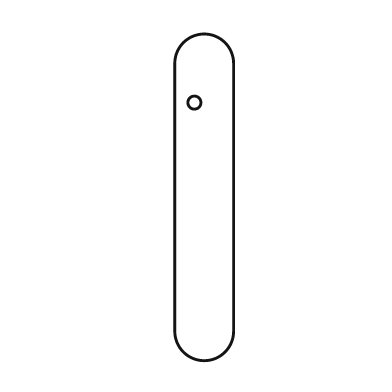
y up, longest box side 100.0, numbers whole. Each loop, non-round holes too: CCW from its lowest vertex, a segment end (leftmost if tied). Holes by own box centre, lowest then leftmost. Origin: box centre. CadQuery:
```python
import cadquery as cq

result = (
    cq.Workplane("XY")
    .moveTo(-9.0, -41.0)
    .threePointArc((0.0, -50.0), (9.0, -41.0))
    .lineTo(9.0, 41.0)
    .threePointArc((0.0, 50.0), (-9.0, 41.0))
    .close()
    .moveTo(-3.0, 29.0)
    .circle(2.0)
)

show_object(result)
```